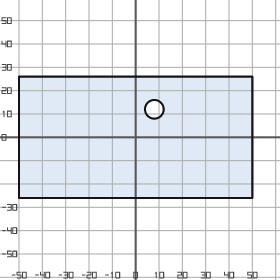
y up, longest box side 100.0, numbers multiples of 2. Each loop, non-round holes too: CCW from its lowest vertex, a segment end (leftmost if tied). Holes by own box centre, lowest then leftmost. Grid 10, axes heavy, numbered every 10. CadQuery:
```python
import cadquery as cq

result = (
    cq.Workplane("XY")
    .moveTo(-50.0, -26.0)
    .lineTo(50.0, -26.0)
    .lineTo(50.0, 26.0)
    .lineTo(-50.0, 26.0)
    .close()
    .moveTo(8.0, 12.0)
    .circle(4.0)
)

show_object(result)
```